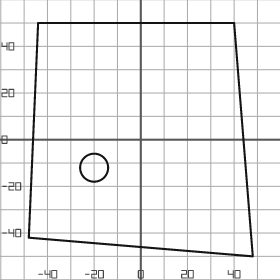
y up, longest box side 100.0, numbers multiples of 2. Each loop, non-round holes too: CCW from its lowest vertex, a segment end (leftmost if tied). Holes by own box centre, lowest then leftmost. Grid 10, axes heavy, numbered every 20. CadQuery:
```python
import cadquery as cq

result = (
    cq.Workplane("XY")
    .moveTo(48.0, -50.0)
    .lineTo(40.0, 50.0)
    .lineTo(-44.0, 50.0)
    .lineTo(-48.0, -42.0)
    .close()
    .moveTo(-20.0, -12.0)
    .circle(6.0)
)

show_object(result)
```